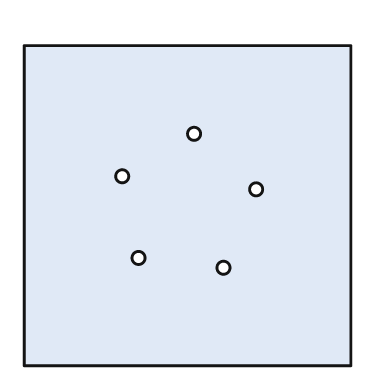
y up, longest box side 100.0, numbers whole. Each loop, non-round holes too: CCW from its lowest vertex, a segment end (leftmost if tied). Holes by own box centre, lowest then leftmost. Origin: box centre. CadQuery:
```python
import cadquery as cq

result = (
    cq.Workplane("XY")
    .moveTo(-50.0, -49.0)
    .lineTo(50.0, -49.0)
    .lineTo(50.0, 49.0)
    .lineTo(-50.0, 49.0)
    .close()
    .moveTo(11.0, -19.0)
    .circle(2.0)
    .moveTo(-15.0, -16.0)
    .circle(2.0)
    .moveTo(21.0, 5.0)
    .circle(2.0)
    .moveTo(-20.0, 9.0)
    .circle(2.0)
    .moveTo(2.0, 22.0)
    .circle(2.0)
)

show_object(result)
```